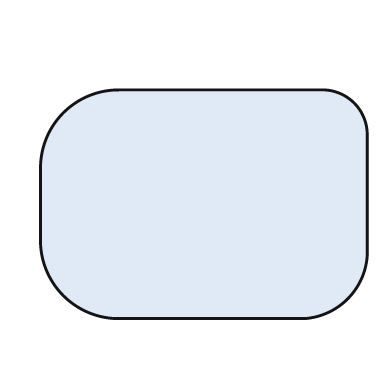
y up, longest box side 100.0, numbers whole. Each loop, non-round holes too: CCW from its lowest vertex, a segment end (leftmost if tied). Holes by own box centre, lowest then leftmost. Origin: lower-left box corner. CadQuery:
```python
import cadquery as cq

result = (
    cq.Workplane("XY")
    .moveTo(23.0, 0.0)
    .lineTo(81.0, 0.0)
    .threePointArc((94.0, 6.0), (100.0, 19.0))
    .lineTo(100.0, 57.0)
    .threePointArc((96.0, 66.0), (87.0, 70.0))
    .lineTo(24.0, 70.0)
    .threePointArc((7.0, 63.0), (0.0, 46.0))
    .lineTo(0.0, 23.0)
    .threePointArc((7.0, 7.0), (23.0, 0.0))
    .close()
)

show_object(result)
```